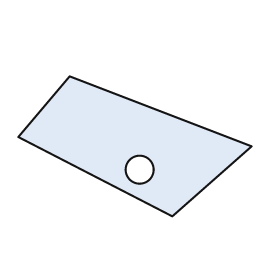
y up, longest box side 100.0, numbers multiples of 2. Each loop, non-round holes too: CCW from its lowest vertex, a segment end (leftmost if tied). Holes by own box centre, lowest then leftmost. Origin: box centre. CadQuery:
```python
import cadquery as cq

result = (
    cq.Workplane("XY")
    .moveTo(16.0, -30.0)
    .lineTo(50.0, 0.0)
    .lineTo(-28.0, 30.0)
    .lineTo(-50.0, 4.0)
    .close()
    .moveTo(2.0, -10.0)
    .circle(6.0)
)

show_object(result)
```